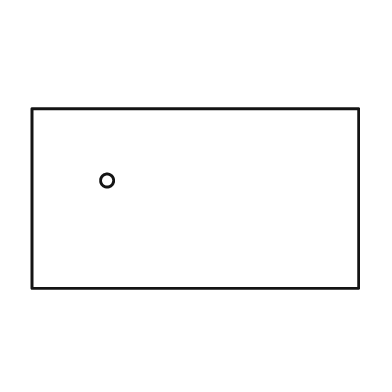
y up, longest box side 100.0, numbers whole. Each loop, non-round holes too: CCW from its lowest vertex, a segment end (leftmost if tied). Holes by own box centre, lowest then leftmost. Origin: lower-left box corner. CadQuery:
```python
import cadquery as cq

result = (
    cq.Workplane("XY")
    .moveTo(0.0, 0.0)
    .lineTo(100.0, 0.0)
    .lineTo(100.0, 55.0)
    .lineTo(0.0, 55.0)
    .close()
    .moveTo(23.0, 33.0)
    .circle(2.0)
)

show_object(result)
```